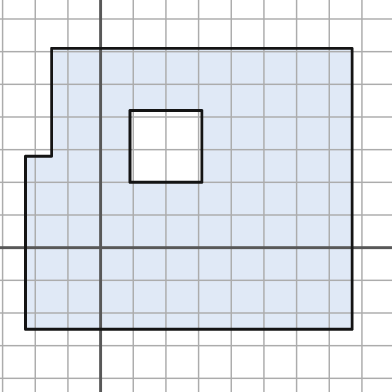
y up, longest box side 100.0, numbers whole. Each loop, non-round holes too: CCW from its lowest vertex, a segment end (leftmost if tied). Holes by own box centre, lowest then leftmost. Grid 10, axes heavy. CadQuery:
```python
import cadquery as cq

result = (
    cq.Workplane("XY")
    .moveTo(-23.0, -25.0)
    .lineTo(77.0, -25.0)
    .lineTo(77.0, 61.0)
    .lineTo(-15.0, 61.0)
    .lineTo(-15.0, 28.0)
    .lineTo(-23.0, 28.0)
    .close()
    .moveTo(9.0, 20.0)
    .lineTo(31.0, 20.0)
    .lineTo(31.0, 42.0)
    .lineTo(9.0, 42.0)
    .close()
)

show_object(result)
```